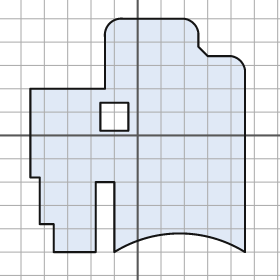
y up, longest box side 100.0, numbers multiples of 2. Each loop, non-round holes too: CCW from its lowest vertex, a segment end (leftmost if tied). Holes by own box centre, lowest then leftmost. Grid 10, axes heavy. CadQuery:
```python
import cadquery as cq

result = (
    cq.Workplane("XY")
    .moveTo(-36.0, -50.0)
    .lineTo(-18.0, -50.0)
    .lineTo(-18.0, -20.0)
    .lineTo(-10.0, -20.0)
    .lineTo(-10.0, -50.0)
    .threePointArc((18.0, -42.0), (46.0, -50.0))
    .lineTo(46.0, 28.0)
    .threePointArc((44.0, 32.0), (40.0, 34.0))
    .lineTo(30.0, 34.0)
    .lineTo(26.0, 38.0)
    .lineTo(26.0, 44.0)
    .threePointArc((24.0, 48.0), (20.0, 50.0))
    .lineTo(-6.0, 50.0)
    .threePointArc((-12.0, 48.0), (-14.0, 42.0))
    .lineTo(-14.0, 20.0)
    .lineTo(-46.0, 20.0)
    .lineTo(-46.0, -18.0)
    .lineTo(-42.0, -18.0)
    .lineTo(-42.0, -38.0)
    .lineTo(-36.0, -38.0)
    .close()
    .moveTo(-16.0, 2.0)
    .lineTo(-4.0, 2.0)
    .lineTo(-4.0, 14.0)
    .lineTo(-16.0, 14.0)
    .close()
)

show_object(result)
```